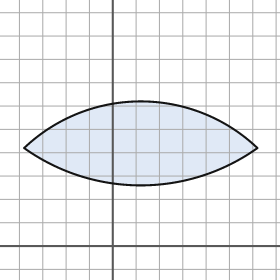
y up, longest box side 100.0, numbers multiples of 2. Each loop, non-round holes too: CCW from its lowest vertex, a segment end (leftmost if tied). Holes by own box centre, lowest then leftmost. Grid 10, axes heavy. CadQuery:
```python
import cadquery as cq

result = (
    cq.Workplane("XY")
    .moveTo(-38.0, 42.0)
    .threePointArc((12.0, 26.0), (62.0, 42.0))
    .threePointArc((12.0, 62.0), (-38.0, 42.0))
    .close()
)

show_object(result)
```